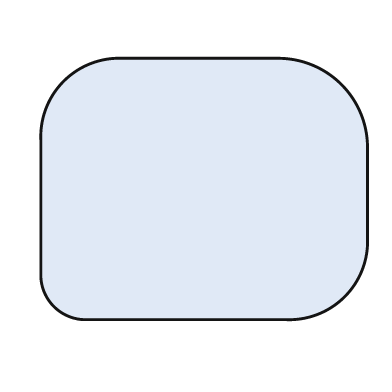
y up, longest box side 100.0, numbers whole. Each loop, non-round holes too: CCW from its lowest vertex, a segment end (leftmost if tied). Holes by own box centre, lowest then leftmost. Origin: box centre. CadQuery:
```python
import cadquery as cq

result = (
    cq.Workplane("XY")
    .moveTo(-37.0, -40.0)
    .lineTo(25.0, -40.0)
    .threePointArc((43.0, -33.0), (50.0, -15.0))
    .lineTo(50.0, 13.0)
    .threePointArc((42.0, 32.0), (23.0, 40.0))
    .lineTo(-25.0, 40.0)
    .threePointArc((-43.0, 33.0), (-50.0, 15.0))
    .lineTo(-50.0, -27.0)
    .threePointArc((-46.0, -36.0), (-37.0, -40.0))
    .close()
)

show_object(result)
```